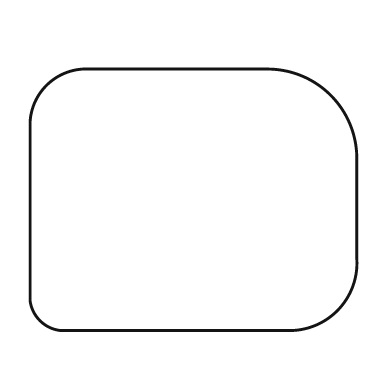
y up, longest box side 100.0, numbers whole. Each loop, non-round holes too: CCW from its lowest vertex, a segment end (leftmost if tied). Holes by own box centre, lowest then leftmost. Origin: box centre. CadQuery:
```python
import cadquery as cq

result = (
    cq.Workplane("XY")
    .moveTo(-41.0, -40.0)
    .lineTo(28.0, -40.0)
    .threePointArc((44.0, -34.0), (50.0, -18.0))
    .lineTo(50.0, 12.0)
    .threePointArc((42.0, 32.0), (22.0, 40.0))
    .lineTo(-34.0, 40.0)
    .threePointArc((-45.0, 35.0), (-50.0, 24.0))
    .lineTo(-50.0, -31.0)
    .threePointArc((-47.0, -37.0), (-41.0, -40.0))
    .close()
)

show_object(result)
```